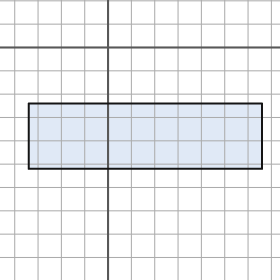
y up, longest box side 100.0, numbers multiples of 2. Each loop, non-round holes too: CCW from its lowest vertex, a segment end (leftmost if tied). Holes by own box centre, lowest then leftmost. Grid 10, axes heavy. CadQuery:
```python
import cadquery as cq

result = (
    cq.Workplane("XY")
    .moveTo(-34.0, -52.0)
    .lineTo(66.0, -52.0)
    .lineTo(66.0, -24.0)
    .lineTo(-34.0, -24.0)
    .close()
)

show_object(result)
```